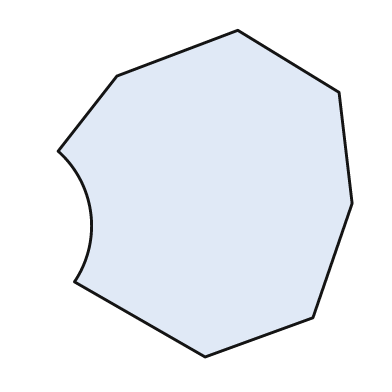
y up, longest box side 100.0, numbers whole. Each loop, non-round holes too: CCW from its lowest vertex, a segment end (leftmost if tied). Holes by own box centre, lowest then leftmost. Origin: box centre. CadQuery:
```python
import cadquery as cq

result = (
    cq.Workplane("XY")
    .moveTo(0.0, -50.0)
    .lineTo(33.0, -38.0)
    .lineTo(45.0, -3.0)
    .lineTo(41.0, 31.0)
    .lineTo(10.0, 50.0)
    .lineTo(-27.0, 36.0)
    .lineTo(-45.0, 13.0)
    .threePointArc((-35.0, -6.0), (-40.0, -27.0))
    .close()
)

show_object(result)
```